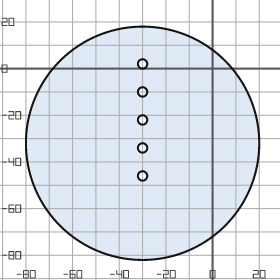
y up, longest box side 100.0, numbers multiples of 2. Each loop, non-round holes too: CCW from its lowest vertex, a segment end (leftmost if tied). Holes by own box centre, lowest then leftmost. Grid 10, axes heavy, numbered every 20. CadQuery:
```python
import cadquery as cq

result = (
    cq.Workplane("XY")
    .moveTo(-30.0, -32.0)
    .circle(50.0)
    .moveTo(-30.0, -46.0)
    .circle(2.0)
    .moveTo(-30.0, -34.0)
    .circle(2.0)
    .moveTo(-30.0, -22.0)
    .circle(2.0)
    .moveTo(-30.0, -10.0)
    .circle(2.0)
    .moveTo(-30.0, 2.0)
    .circle(2.0)
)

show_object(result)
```